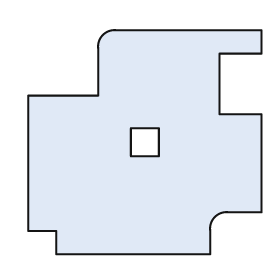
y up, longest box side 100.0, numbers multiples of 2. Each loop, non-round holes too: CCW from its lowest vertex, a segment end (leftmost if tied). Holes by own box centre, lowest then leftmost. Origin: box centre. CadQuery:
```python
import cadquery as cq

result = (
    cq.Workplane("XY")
    .moveTo(-38.0, -48.0)
    .lineTo(28.0, -48.0)
    .lineTo(28.0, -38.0)
    .threePointArc((30.0, -32.0), (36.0, -30.0))
    .lineTo(50.0, -30.0)
    .lineTo(50.0, 12.0)
    .lineTo(32.0, 12.0)
    .lineTo(32.0, 38.0)
    .lineTo(50.0, 38.0)
    .lineTo(50.0, 48.0)
    .lineTo(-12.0, 48.0)
    .threePointArc((-18.0, 46.0), (-20.0, 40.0))
    .lineTo(-20.0, 20.0)
    .lineTo(-50.0, 20.0)
    .lineTo(-50.0, -38.0)
    .lineTo(-38.0, -38.0)
    .close()
    .moveTo(-6.0, -6.0)
    .lineTo(6.0, -6.0)
    .lineTo(6.0, 6.0)
    .lineTo(-6.0, 6.0)
    .close()
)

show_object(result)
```